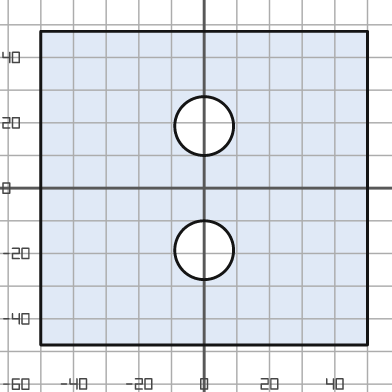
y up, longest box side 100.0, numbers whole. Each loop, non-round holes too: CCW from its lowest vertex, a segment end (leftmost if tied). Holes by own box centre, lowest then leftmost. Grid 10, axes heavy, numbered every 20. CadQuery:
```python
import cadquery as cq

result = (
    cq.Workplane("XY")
    .moveTo(-50.0, -48.0)
    .lineTo(50.0, -48.0)
    .lineTo(50.0, 48.0)
    .lineTo(-50.0, 48.0)
    .close()
    .moveTo(0.0, -19.0)
    .circle(9.0)
    .moveTo(0.0, 19.0)
    .circle(9.0)
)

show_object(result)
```